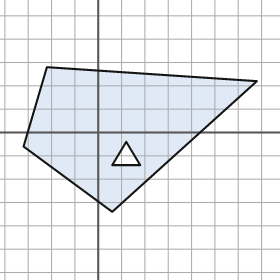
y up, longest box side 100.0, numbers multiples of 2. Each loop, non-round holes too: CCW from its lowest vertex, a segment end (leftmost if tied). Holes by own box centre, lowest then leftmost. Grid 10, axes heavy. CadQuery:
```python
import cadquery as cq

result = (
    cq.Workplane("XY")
    .moveTo(6.0, -34.0)
    .lineTo(68.0, 22.0)
    .lineTo(-22.0, 28.0)
    .lineTo(-32.0, -6.0)
    .close()
    .moveTo(6.0, -14.0)
    .lineTo(18.0, -14.0)
    .lineTo(12.0, -4.0)
    .close()
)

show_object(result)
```